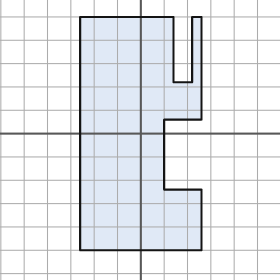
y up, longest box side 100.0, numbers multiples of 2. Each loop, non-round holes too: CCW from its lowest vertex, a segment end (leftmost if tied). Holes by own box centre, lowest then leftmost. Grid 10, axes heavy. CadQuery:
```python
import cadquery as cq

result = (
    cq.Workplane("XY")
    .moveTo(-26.0, -50.0)
    .lineTo(26.0, -50.0)
    .lineTo(26.0, -24.0)
    .lineTo(10.0, -24.0)
    .lineTo(10.0, 6.0)
    .lineTo(26.0, 6.0)
    .lineTo(26.0, 50.0)
    .lineTo(22.0, 50.0)
    .lineTo(22.0, 22.0)
    .lineTo(14.0, 22.0)
    .lineTo(14.0, 50.0)
    .lineTo(-26.0, 50.0)
    .close()
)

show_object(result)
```